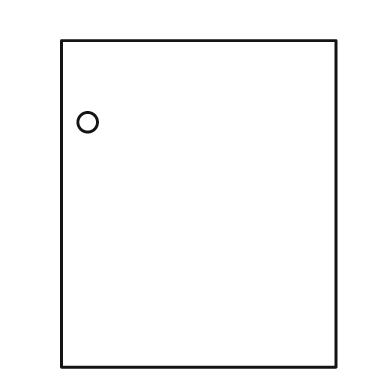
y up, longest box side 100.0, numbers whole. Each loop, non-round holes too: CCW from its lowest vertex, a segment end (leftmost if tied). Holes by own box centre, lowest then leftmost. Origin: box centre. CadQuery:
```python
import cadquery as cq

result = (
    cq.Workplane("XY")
    .moveTo(-42.0, -50.0)
    .lineTo(42.0, -50.0)
    .lineTo(42.0, 50.0)
    .lineTo(-42.0, 50.0)
    .close()
    .moveTo(-34.0, 25.0)
    .circle(3.0)
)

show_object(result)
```